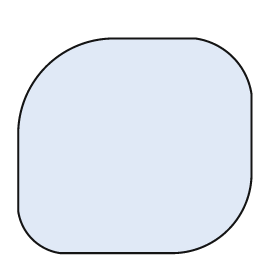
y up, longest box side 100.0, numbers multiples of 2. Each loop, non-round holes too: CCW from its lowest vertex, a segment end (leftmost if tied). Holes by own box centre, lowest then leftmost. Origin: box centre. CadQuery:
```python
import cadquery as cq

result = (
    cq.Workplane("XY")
    .moveTo(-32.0, -46.0)
    .lineTo(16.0, -46.0)
    .threePointArc((40.0, -36.0), (50.0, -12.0))
    .lineTo(50.0, 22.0)
    .threePointArc((42.0, 38.0), (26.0, 46.0))
    .lineTo(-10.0, 46.0)
    .threePointArc((-38.0, 34.0), (-50.0, 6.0))
    .lineTo(-50.0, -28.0)
    .threePointArc((-44.0, -40.0), (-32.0, -46.0))
    .close()
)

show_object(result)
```